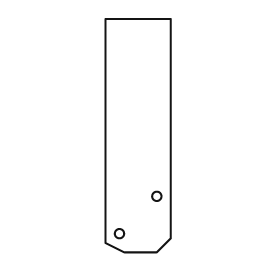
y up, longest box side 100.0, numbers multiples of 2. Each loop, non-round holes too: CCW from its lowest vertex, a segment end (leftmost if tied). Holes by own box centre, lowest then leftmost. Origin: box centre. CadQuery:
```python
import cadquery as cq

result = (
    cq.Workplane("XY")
    .moveTo(-6.0, -50.0)
    .lineTo(8.0, -50.0)
    .lineTo(14.0, -44.0)
    .lineTo(14.0, 50.0)
    .lineTo(-14.0, 50.0)
    .lineTo(-14.0, -46.0)
    .close()
    .moveTo(-8.0, -42.0)
    .circle(2.0)
    .moveTo(8.0, -26.0)
    .circle(2.0)
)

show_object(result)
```